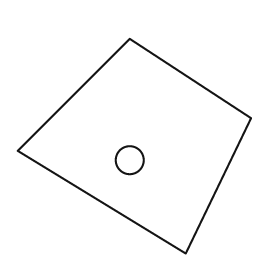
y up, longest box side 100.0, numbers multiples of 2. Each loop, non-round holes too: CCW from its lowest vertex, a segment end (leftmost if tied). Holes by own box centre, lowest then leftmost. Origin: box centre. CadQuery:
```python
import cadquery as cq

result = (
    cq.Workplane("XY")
    .moveTo(22.0, -46.0)
    .lineTo(50.0, 12.0)
    .lineTo(-2.0, 46.0)
    .lineTo(-50.0, -2.0)
    .close()
    .moveTo(-2.0, -6.0)
    .circle(6.0)
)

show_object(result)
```